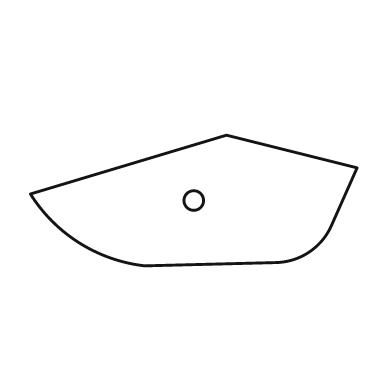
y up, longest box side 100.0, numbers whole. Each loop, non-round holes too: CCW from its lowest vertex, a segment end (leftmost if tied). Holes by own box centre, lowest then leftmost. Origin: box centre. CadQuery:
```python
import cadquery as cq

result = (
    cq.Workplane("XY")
    .moveTo(-15.0, -20.0)
    .lineTo(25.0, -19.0)
    .threePointArc((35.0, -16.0), (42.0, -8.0))
    .lineTo(50.0, 10.0)
    .lineTo(10.0, 20.0)
    .lineTo(-50.0, 2.0)
    .threePointArc((-35.0, -13.0), (-15.0, -20.0))
    .close()
    .moveTo(0.0, 0.0)
    .circle(3.0)
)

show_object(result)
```